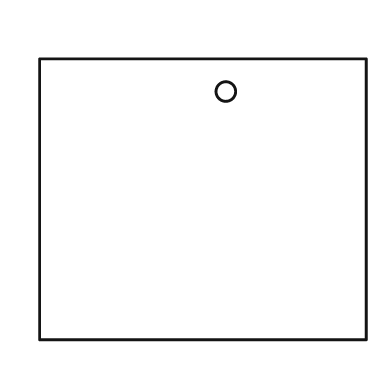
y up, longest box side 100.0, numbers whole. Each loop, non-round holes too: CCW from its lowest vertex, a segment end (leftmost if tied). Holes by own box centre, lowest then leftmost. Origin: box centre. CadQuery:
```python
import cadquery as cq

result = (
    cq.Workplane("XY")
    .moveTo(-50.0, -43.0)
    .lineTo(50.0, -43.0)
    .lineTo(50.0, 43.0)
    .lineTo(-50.0, 43.0)
    .close()
    .moveTo(7.0, 33.0)
    .circle(3.0)
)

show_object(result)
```